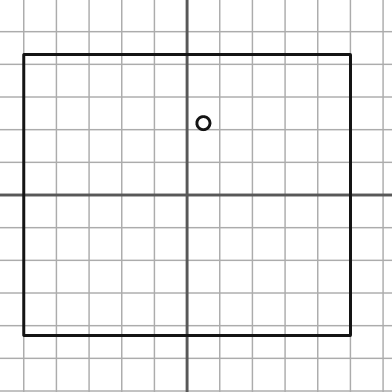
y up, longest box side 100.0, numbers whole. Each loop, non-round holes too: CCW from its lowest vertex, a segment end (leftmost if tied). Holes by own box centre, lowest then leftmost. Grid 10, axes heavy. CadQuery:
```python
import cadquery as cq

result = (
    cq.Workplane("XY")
    .moveTo(-50.0, -43.0)
    .lineTo(50.0, -43.0)
    .lineTo(50.0, 43.0)
    .lineTo(-50.0, 43.0)
    .close()
    .moveTo(5.0, 22.0)
    .circle(2.0)
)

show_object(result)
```